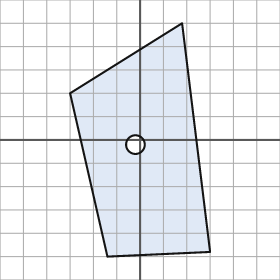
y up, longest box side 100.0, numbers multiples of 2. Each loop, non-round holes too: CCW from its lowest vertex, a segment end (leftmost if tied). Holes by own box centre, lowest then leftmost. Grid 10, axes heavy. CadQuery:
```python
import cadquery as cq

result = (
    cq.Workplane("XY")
    .moveTo(-14.0, -50.0)
    .lineTo(30.0, -48.0)
    .lineTo(18.0, 50.0)
    .lineTo(-30.0, 20.0)
    .close()
    .moveTo(-2.0, -2.0)
    .circle(4.0)
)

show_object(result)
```